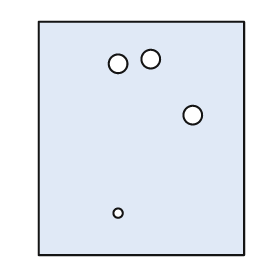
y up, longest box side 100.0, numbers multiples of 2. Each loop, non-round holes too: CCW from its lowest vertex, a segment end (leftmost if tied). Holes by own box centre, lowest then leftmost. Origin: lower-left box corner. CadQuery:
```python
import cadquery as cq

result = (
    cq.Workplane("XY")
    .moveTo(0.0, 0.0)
    .lineTo(88.0, 0.0)
    .lineTo(88.0, 100.0)
    .lineTo(0.0, 100.0)
    .close()
    .moveTo(34.0, 18.0)
    .circle(2.0)
    .moveTo(66.0, 60.0)
    .circle(4.0)
    .moveTo(34.0, 82.0)
    .circle(4.0)
    .moveTo(48.0, 84.0)
    .circle(4.0)
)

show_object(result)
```